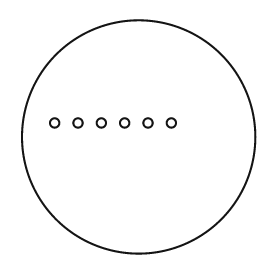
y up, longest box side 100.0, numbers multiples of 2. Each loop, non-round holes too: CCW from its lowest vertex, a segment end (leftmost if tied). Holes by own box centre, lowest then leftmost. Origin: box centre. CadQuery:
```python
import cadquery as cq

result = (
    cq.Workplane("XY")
    .moveTo(0.0, 0.0)
    .circle(50.0)
    .moveTo(-36.0, 6.0)
    .circle(2.0)
    .moveTo(-26.0, 6.0)
    .circle(2.0)
    .moveTo(-16.0, 6.0)
    .circle(2.0)
    .moveTo(-6.0, 6.0)
    .circle(2.0)
    .moveTo(4.0, 6.0)
    .circle(2.0)
    .moveTo(14.0, 6.0)
    .circle(2.0)
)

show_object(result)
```